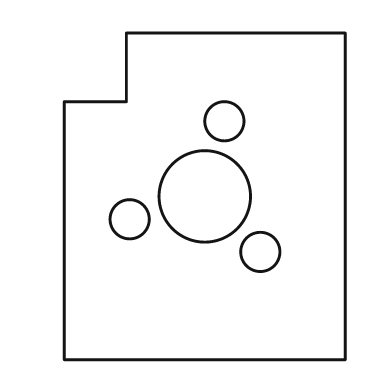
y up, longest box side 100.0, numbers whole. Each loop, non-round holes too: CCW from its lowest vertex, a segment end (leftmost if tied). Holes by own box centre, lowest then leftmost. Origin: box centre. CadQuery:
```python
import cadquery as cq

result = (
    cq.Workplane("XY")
    .moveTo(-43.0, -50.0)
    .lineTo(43.0, -50.0)
    .lineTo(43.0, 50.0)
    .lineTo(-24.0, 50.0)
    .lineTo(-24.0, 29.0)
    .lineTo(-43.0, 29.0)
    .close()
    .moveTo(17.0, -17.0)
    .circle(6.0)
    .moveTo(-23.0, -7.0)
    .circle(6.0)
    .moveTo(0.0, 0.0)
    .circle(14.0)
    .moveTo(6.0, 23.0)
    .circle(6.0)
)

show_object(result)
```